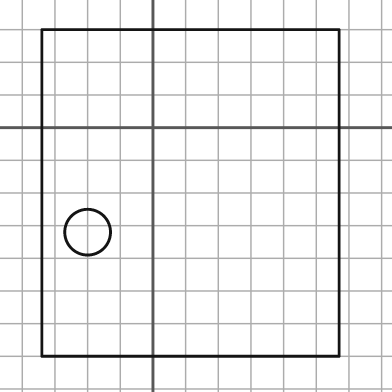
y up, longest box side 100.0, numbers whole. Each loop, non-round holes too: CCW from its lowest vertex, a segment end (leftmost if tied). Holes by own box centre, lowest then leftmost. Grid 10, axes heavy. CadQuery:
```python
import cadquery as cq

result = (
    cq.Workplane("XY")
    .moveTo(-34.0, -70.0)
    .lineTo(57.0, -70.0)
    .lineTo(57.0, 30.0)
    .lineTo(-34.0, 30.0)
    .close()
    .moveTo(-20.0, -32.0)
    .circle(7.0)
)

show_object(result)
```